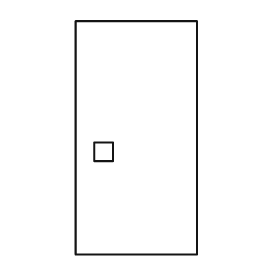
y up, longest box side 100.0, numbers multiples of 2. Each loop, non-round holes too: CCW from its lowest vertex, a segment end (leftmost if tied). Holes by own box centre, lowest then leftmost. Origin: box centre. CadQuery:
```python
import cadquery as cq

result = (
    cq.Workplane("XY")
    .moveTo(-26.0, -50.0)
    .lineTo(26.0, -50.0)
    .lineTo(26.0, 50.0)
    .lineTo(-26.0, 50.0)
    .close()
    .moveTo(-18.0, -10.0)
    .lineTo(-10.0, -10.0)
    .lineTo(-10.0, -2.0)
    .lineTo(-18.0, -2.0)
    .close()
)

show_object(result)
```